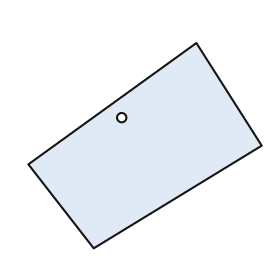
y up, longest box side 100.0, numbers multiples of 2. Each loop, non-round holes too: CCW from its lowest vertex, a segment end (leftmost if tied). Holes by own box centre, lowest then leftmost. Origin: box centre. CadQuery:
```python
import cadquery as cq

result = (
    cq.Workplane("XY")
    .moveTo(-22.0, -44.0)
    .lineTo(50.0, 0.0)
    .lineTo(22.0, 44.0)
    .lineTo(-50.0, -8.0)
    .close()
    .moveTo(-10.0, 12.0)
    .circle(2.0)
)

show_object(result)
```